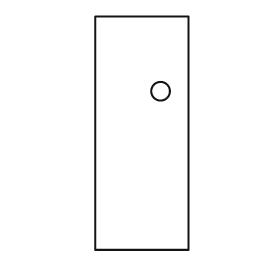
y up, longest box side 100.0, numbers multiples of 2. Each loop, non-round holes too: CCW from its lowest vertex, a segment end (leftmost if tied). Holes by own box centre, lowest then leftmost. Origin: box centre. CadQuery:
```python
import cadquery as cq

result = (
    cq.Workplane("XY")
    .moveTo(-20.0, -50.0)
    .lineTo(20.0, -50.0)
    .lineTo(20.0, 50.0)
    .lineTo(-20.0, 50.0)
    .close()
    .moveTo(8.0, 18.0)
    .circle(4.0)
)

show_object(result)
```